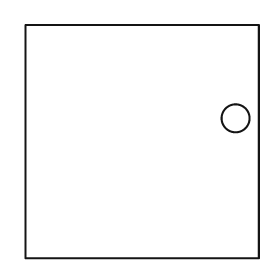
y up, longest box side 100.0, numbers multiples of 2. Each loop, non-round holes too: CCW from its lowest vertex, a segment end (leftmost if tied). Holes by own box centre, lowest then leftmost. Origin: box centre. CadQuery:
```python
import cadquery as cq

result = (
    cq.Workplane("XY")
    .moveTo(-50.0, -50.0)
    .lineTo(50.0, -50.0)
    .lineTo(50.0, 50.0)
    .lineTo(-50.0, 50.0)
    .close()
    .moveTo(40.0, 10.0)
    .circle(6.0)
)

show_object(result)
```